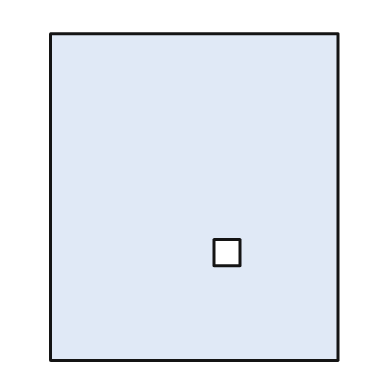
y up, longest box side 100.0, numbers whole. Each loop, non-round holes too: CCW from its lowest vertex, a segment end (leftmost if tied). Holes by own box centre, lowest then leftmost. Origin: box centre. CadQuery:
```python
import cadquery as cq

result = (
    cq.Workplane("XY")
    .moveTo(-44.0, -50.0)
    .lineTo(44.0, -50.0)
    .lineTo(44.0, 50.0)
    .lineTo(-44.0, 50.0)
    .close()
    .moveTo(6.0, -21.0)
    .lineTo(14.0, -21.0)
    .lineTo(14.0, -13.0)
    .lineTo(6.0, -13.0)
    .close()
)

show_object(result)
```